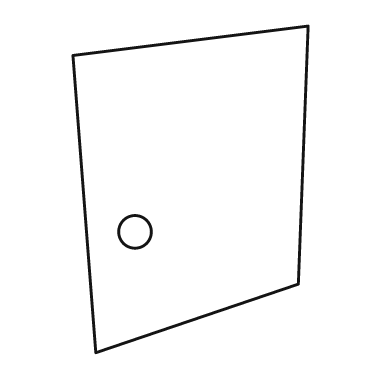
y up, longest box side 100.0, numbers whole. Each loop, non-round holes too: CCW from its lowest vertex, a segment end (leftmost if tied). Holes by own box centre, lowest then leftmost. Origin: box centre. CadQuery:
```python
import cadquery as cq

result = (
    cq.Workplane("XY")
    .moveTo(-29.0, -50.0)
    .lineTo(33.0, -29.0)
    .lineTo(36.0, 50.0)
    .lineTo(-36.0, 41.0)
    .close()
    .moveTo(-17.0, -13.0)
    .circle(5.0)
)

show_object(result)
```